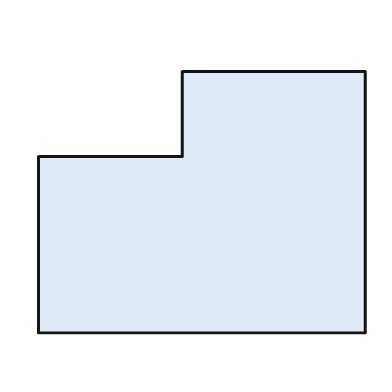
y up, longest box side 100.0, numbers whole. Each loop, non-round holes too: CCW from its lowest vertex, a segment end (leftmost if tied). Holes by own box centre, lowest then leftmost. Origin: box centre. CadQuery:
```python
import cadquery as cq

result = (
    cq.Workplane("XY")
    .moveTo(-50.0, -40.0)
    .lineTo(50.0, -40.0)
    .lineTo(50.0, 40.0)
    .lineTo(-6.0, 40.0)
    .lineTo(-6.0, 14.0)
    .lineTo(-50.0, 14.0)
    .close()
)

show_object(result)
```